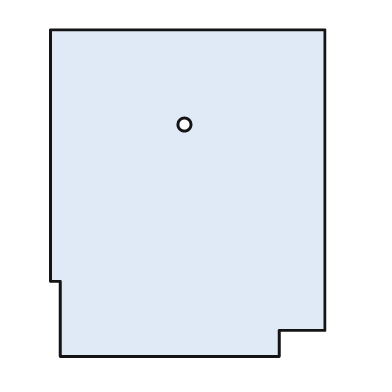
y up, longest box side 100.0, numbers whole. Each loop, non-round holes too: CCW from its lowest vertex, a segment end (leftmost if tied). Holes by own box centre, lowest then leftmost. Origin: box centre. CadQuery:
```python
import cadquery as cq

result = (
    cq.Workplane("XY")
    .moveTo(-39.0, -50.0)
    .lineTo(28.0, -50.0)
    .lineTo(28.0, -42.0)
    .lineTo(42.0, -42.0)
    .lineTo(42.0, 50.0)
    .lineTo(-42.0, 50.0)
    .lineTo(-42.0, -27.0)
    .lineTo(-39.0, -27.0)
    .close()
    .moveTo(-1.0, 21.0)
    .circle(2.0)
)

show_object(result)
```